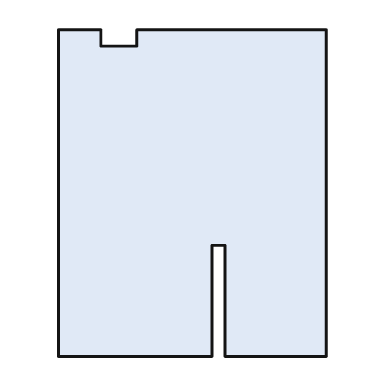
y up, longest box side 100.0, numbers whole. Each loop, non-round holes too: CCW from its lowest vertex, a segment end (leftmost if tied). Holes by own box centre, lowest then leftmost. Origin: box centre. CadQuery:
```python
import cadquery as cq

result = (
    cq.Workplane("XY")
    .moveTo(-41.0, -50.0)
    .lineTo(6.0, -50.0)
    .lineTo(6.0, -16.0)
    .lineTo(10.0, -16.0)
    .lineTo(10.0, -50.0)
    .lineTo(41.0, -50.0)
    .lineTo(41.0, 50.0)
    .lineTo(-17.0, 50.0)
    .lineTo(-17.0, 45.0)
    .lineTo(-28.0, 45.0)
    .lineTo(-28.0, 50.0)
    .lineTo(-41.0, 50.0)
    .close()
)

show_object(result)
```